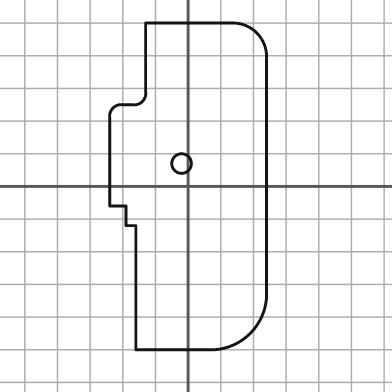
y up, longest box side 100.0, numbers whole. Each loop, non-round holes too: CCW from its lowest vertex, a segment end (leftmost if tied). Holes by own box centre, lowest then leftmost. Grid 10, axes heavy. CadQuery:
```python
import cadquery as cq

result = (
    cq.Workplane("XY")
    .moveTo(-16.0, -50.0)
    .lineTo(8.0, -50.0)
    .threePointArc((19.0, -45.0), (24.0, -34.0))
    .lineTo(24.0, 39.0)
    .threePointArc((21.0, 47.0), (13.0, 50.0))
    .lineTo(-13.0, 50.0)
    .lineTo(-13.0, 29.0)
    .threePointArc((-14.0, 26.0), (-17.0, 25.0))
    .lineTo(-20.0, 25.0)
    .threePointArc((-23.0, 24.0), (-24.0, 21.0))
    .lineTo(-24.0, -6.0)
    .lineTo(-19.0, -6.0)
    .lineTo(-19.0, -12.0)
    .lineTo(-16.0, -12.0)
    .close()
    .moveTo(-2.0, 7.0)
    .circle(3.0)
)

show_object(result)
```